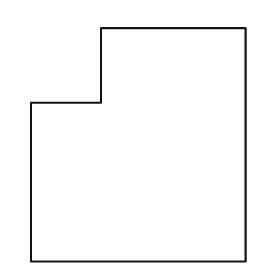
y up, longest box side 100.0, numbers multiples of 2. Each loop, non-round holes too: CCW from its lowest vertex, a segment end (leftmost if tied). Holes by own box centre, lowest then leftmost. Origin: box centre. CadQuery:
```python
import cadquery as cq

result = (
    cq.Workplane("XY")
    .moveTo(-46.0, -50.0)
    .lineTo(46.0, -50.0)
    .lineTo(46.0, 50.0)
    .lineTo(-16.0, 50.0)
    .lineTo(-16.0, 18.0)
    .lineTo(-46.0, 18.0)
    .close()
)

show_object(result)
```